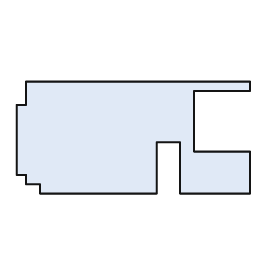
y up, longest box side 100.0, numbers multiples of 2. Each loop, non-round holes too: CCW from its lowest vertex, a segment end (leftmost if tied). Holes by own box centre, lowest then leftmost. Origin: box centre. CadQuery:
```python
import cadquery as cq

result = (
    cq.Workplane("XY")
    .moveTo(-40.0, -24.0)
    .lineTo(10.0, -24.0)
    .lineTo(10.0, -2.0)
    .lineTo(20.0, -2.0)
    .lineTo(20.0, -24.0)
    .lineTo(50.0, -24.0)
    .lineTo(50.0, -6.0)
    .lineTo(26.0, -6.0)
    .lineTo(26.0, 20.0)
    .lineTo(50.0, 20.0)
    .lineTo(50.0, 24.0)
    .lineTo(-46.0, 24.0)
    .lineTo(-46.0, 14.0)
    .lineTo(-50.0, 14.0)
    .lineTo(-50.0, -16.0)
    .lineTo(-46.0, -16.0)
    .lineTo(-46.0, -20.0)
    .lineTo(-40.0, -20.0)
    .close()
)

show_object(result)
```